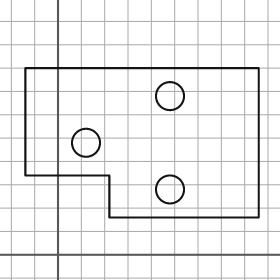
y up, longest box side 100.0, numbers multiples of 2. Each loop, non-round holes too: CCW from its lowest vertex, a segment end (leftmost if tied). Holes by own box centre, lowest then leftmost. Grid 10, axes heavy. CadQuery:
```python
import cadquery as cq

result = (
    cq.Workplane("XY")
    .moveTo(22.0, 16.0)
    .lineTo(86.0, 16.0)
    .lineTo(86.0, 80.0)
    .lineTo(-14.0, 80.0)
    .lineTo(-14.0, 34.0)
    .lineTo(22.0, 34.0)
    .close()
    .moveTo(48.0, 28.0)
    .circle(6.0)
    .moveTo(12.0, 48.0)
    .circle(6.0)
    .moveTo(48.0, 68.0)
    .circle(6.0)
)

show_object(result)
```